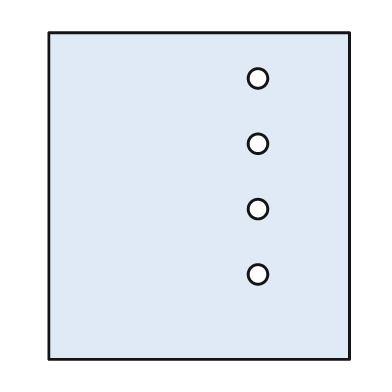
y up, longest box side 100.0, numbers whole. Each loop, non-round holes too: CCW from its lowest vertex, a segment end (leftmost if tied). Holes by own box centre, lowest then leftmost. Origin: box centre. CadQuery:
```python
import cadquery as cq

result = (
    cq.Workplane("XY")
    .moveTo(-46.0, -50.0)
    .lineTo(46.0, -50.0)
    .lineTo(46.0, 50.0)
    .lineTo(-46.0, 50.0)
    .close()
    .moveTo(18.0, -24.0)
    .circle(3.0)
    .moveTo(18.0, -4.0)
    .circle(3.0)
    .moveTo(18.0, 16.0)
    .circle(3.0)
    .moveTo(18.0, 36.0)
    .circle(3.0)
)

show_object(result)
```